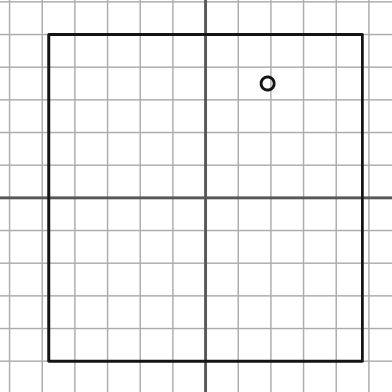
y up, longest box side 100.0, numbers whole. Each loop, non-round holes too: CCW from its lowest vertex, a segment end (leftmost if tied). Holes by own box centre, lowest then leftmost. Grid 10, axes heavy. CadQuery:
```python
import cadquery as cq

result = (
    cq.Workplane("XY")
    .moveTo(-48.0, -50.0)
    .lineTo(48.0, -50.0)
    .lineTo(48.0, 50.0)
    .lineTo(-48.0, 50.0)
    .close()
    .moveTo(19.0, 35.0)
    .circle(2.0)
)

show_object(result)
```